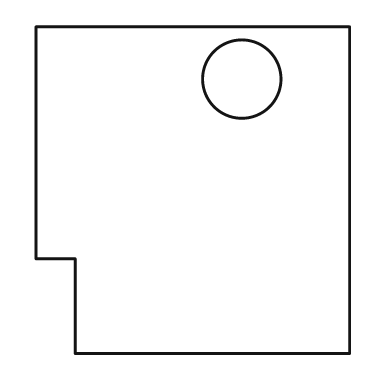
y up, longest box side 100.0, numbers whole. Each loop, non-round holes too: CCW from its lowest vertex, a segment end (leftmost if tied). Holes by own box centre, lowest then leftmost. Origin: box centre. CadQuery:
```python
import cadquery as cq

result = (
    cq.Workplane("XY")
    .moveTo(-36.0, -50.0)
    .lineTo(48.0, -50.0)
    .lineTo(48.0, 50.0)
    .lineTo(-48.0, 50.0)
    .lineTo(-48.0, -21.0)
    .lineTo(-36.0, -21.0)
    .close()
    .moveTo(15.0, 34.0)
    .circle(12.0)
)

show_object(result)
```